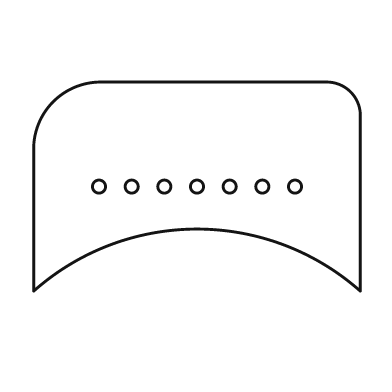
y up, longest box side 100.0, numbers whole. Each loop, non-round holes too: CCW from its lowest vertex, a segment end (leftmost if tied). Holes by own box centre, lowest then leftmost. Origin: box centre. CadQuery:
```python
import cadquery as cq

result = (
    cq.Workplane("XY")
    .moveTo(-50.0, -32.0)
    .threePointArc((0.0, -13.0), (50.0, -32.0))
    .lineTo(50.0, 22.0)
    .threePointArc((47.0, 29.0), (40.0, 32.0))
    .lineTo(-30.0, 32.0)
    .threePointArc((-44.0, 26.0), (-50.0, 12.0))
    .close()
    .moveTo(-30.0, 0.0)
    .circle(2.0)
    .moveTo(-20.0, 0.0)
    .circle(2.0)
    .moveTo(-10.0, 0.0)
    .circle(2.0)
    .moveTo(0.0, 0.0)
    .circle(2.0)
    .moveTo(10.0, 0.0)
    .circle(2.0)
    .moveTo(20.0, 0.0)
    .circle(2.0)
    .moveTo(30.0, 0.0)
    .circle(2.0)
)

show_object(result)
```